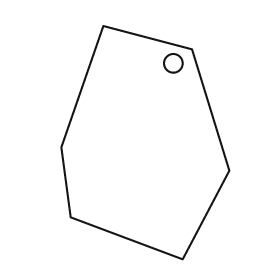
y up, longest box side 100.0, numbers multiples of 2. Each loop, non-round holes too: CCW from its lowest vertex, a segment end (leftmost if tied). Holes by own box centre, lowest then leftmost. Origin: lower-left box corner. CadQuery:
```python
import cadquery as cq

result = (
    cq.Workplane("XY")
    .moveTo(52.0, 0.0)
    .lineTo(72.0, 38.0)
    .lineTo(56.0, 90.0)
    .lineTo(18.0, 100.0)
    .lineTo(0.0, 48.0)
    .lineTo(4.0, 18.0)
    .close()
    .moveTo(48.0, 84.0)
    .circle(4.0)
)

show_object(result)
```